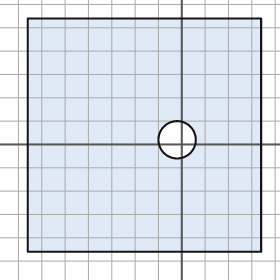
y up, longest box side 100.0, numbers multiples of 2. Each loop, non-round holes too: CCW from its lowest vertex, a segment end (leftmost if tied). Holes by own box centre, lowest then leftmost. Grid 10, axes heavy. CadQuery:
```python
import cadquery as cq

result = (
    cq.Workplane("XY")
    .moveTo(-66.0, -46.0)
    .lineTo(34.0, -46.0)
    .lineTo(34.0, 54.0)
    .lineTo(-66.0, 54.0)
    .close()
    .moveTo(-2.0, 2.0)
    .circle(8.0)
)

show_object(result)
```